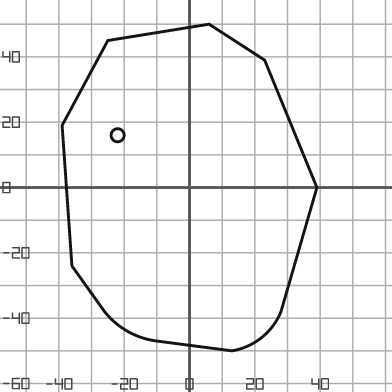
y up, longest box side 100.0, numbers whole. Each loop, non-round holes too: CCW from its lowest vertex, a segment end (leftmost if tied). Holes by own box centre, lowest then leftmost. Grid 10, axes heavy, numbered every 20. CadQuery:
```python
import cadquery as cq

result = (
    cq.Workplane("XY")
    .moveTo(13.0, -50.0)
    .threePointArc((22.0, -46.0), (28.0, -38.0))
    .lineTo(39.0, 0.0)
    .lineTo(23.0, 39.0)
    .lineTo(6.0, 50.0)
    .lineTo(-25.0, 45.0)
    .lineTo(-39.0, 19.0)
    .lineTo(-36.0, -24.0)
    .lineTo(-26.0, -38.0)
    .threePointArc((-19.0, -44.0), (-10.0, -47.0))
    .close()
    .moveTo(-22.0, 16.0)
    .circle(2.0)
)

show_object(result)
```